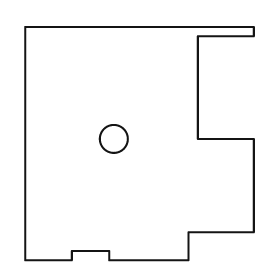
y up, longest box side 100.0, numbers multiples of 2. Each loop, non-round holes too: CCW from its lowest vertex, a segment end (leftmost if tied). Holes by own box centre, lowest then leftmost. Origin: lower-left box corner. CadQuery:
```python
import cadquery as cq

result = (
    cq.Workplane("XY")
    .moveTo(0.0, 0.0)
    .lineTo(20.0, 0.0)
    .lineTo(20.0, 4.0)
    .lineTo(36.0, 4.0)
    .lineTo(36.0, 0.0)
    .lineTo(70.0, 0.0)
    .lineTo(70.0, 12.0)
    .lineTo(98.0, 12.0)
    .lineTo(98.0, 52.0)
    .lineTo(74.0, 52.0)
    .lineTo(74.0, 96.0)
    .lineTo(98.0, 96.0)
    .lineTo(98.0, 100.0)
    .lineTo(0.0, 100.0)
    .close()
    .moveTo(38.0, 52.0)
    .circle(6.0)
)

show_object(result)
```